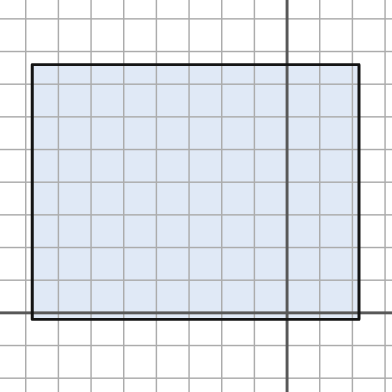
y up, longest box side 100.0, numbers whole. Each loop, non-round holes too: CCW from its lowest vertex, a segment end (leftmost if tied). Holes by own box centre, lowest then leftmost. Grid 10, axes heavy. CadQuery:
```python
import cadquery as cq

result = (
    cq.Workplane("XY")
    .moveTo(-78.0, -2.0)
    .lineTo(22.0, -2.0)
    .lineTo(22.0, 76.0)
    .lineTo(-78.0, 76.0)
    .close()
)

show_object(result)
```